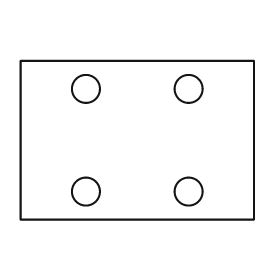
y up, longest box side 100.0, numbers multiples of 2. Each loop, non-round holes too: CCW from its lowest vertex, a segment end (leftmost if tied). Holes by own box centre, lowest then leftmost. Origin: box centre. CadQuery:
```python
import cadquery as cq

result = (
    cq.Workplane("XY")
    .moveTo(-50.0, -34.0)
    .lineTo(50.0, -34.0)
    .lineTo(50.0, 34.0)
    .lineTo(-50.0, 34.0)
    .close()
    .moveTo(-22.0, -22.0)
    .circle(6.0)
    .moveTo(22.0, -22.0)
    .circle(6.0)
    .moveTo(-22.0, 22.0)
    .circle(6.0)
    .moveTo(22.0, 22.0)
    .circle(6.0)
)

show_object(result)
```